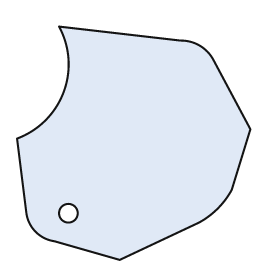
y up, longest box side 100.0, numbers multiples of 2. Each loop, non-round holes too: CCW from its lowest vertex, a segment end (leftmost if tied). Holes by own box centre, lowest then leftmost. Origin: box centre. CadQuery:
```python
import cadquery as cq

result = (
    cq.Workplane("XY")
    .moveTo(-6.0, -50.0)
    .lineTo(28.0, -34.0)
    .threePointArc((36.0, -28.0), (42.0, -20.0))
    .lineTo(50.0, 6.0)
    .lineTo(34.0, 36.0)
    .threePointArc((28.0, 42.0), (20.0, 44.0))
    .lineTo(-32.0, 50.0)
    .threePointArc((-30.0, 22.0), (-50.0, 2.0))
    .lineTo(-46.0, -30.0)
    .threePointArc((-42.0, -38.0), (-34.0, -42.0))
    .close()
    .moveTo(-28.0, -30.0)
    .circle(4.0)
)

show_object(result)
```